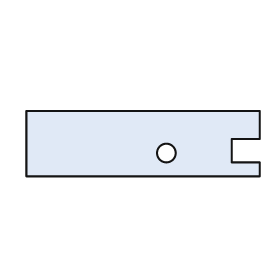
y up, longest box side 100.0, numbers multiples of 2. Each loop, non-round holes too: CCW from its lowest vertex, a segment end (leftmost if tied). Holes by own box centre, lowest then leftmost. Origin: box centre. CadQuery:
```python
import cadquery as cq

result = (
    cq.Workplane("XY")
    .moveTo(-50.0, -14.0)
    .lineTo(50.0, -14.0)
    .lineTo(50.0, -8.0)
    .lineTo(38.0, -8.0)
    .lineTo(38.0, 2.0)
    .lineTo(50.0, 2.0)
    .lineTo(50.0, 14.0)
    .lineTo(-50.0, 14.0)
    .close()
    .moveTo(10.0, -4.0)
    .circle(4.0)
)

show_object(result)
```